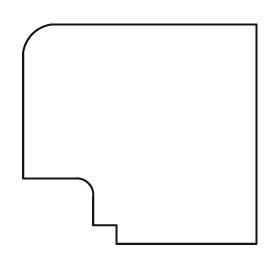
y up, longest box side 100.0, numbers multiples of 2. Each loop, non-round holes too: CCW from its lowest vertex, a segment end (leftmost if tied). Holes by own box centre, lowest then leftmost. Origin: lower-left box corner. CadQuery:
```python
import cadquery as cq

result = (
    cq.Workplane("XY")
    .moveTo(40.0, 0.0)
    .lineTo(100.0, 0.0)
    .lineTo(100.0, 94.0)
    .lineTo(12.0, 94.0)
    .threePointArc((4.0, 90.0), (0.0, 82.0))
    .lineTo(0.0, 28.0)
    .lineTo(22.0, 28.0)
    .threePointArc((28.0, 26.0), (30.0, 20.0))
    .lineTo(30.0, 8.0)
    .lineTo(40.0, 8.0)
    .close()
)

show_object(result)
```